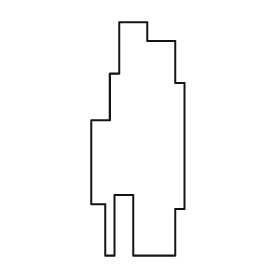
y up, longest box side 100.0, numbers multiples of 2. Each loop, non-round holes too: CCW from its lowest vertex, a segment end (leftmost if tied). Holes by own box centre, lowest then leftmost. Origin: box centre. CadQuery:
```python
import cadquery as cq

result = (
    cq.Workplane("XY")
    .moveTo(-14.0, -50.0)
    .lineTo(-10.0, -50.0)
    .lineTo(-10.0, -24.0)
    .lineTo(-2.0, -24.0)
    .lineTo(-2.0, -50.0)
    .lineTo(16.0, -50.0)
    .lineTo(16.0, -30.0)
    .lineTo(20.0, -30.0)
    .lineTo(20.0, 24.0)
    .lineTo(16.0, 24.0)
    .lineTo(16.0, 42.0)
    .lineTo(4.0, 42.0)
    .lineTo(4.0, 50.0)
    .lineTo(-8.0, 50.0)
    .lineTo(-8.0, 28.0)
    .lineTo(-12.0, 28.0)
    .lineTo(-12.0, 8.0)
    .lineTo(-20.0, 8.0)
    .lineTo(-20.0, -28.0)
    .lineTo(-14.0, -28.0)
    .close()
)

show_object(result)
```